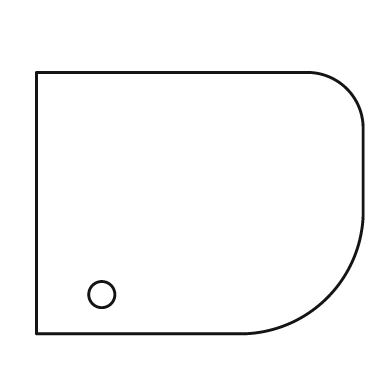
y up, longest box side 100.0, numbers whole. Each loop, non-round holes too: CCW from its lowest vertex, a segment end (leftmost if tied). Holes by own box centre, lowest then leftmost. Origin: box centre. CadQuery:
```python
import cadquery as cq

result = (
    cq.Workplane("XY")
    .moveTo(-50.0, -40.0)
    .lineTo(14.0, -40.0)
    .threePointArc((39.0, -29.0), (50.0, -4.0))
    .lineTo(50.0, 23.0)
    .threePointArc((45.0, 35.0), (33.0, 40.0))
    .lineTo(-50.0, 40.0)
    .close()
    .moveTo(-30.0, -28.0)
    .circle(4.0)
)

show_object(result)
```